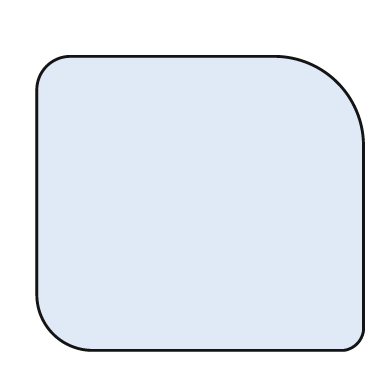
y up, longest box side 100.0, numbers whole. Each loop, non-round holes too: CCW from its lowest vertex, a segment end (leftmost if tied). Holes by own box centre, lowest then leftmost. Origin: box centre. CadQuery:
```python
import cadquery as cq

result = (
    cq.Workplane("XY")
    .moveTo(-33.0, -45.0)
    .lineTo(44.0, -45.0)
    .threePointArc((48.0, -43.0), (50.0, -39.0))
    .lineTo(50.0, 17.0)
    .threePointArc((42.0, 37.0), (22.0, 45.0))
    .lineTo(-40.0, 45.0)
    .threePointArc((-47.0, 42.0), (-50.0, 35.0))
    .lineTo(-50.0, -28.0)
    .threePointArc((-45.0, -40.0), (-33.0, -45.0))
    .close()
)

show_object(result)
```